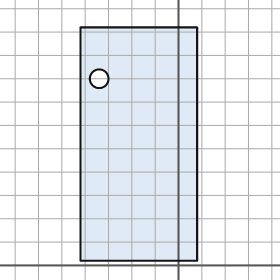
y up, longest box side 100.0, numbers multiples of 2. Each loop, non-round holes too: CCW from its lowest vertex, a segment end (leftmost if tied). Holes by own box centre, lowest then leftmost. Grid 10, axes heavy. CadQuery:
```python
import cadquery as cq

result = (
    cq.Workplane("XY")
    .moveTo(-42.0, 2.0)
    .lineTo(8.0, 2.0)
    .lineTo(8.0, 102.0)
    .lineTo(-42.0, 102.0)
    .close()
    .moveTo(-34.0, 80.0)
    .circle(4.0)
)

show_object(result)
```